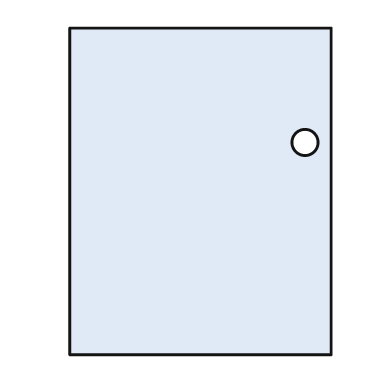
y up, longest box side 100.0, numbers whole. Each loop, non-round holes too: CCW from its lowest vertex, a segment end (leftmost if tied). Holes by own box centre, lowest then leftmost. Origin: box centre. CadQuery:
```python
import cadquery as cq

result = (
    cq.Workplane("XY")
    .moveTo(-40.0, -50.0)
    .lineTo(40.0, -50.0)
    .lineTo(40.0, 50.0)
    .lineTo(-40.0, 50.0)
    .close()
    .moveTo(32.0, 15.0)
    .circle(4.0)
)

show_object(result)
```